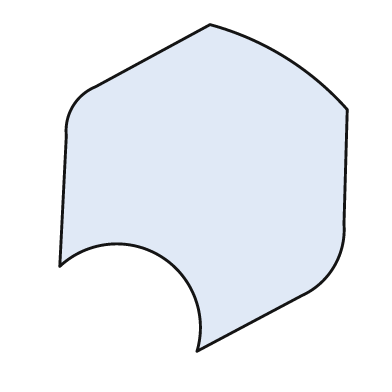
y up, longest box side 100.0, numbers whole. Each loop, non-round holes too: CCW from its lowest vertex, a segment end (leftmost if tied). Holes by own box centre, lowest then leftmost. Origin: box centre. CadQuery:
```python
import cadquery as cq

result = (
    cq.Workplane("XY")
    .moveTo(-2.0, -50.0)
    .lineTo(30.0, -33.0)
    .threePointArc((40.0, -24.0), (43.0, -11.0))
    .lineTo(44.0, 24.0)
    .threePointArc((25.0, 40.0), (2.0, 50.0))
    .lineTo(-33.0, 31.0)
    .threePointArc((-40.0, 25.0), (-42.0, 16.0))
    .lineTo(-44.0, -24.0)
    .threePointArc((-13.0, -21.0), (-2.0, -50.0))
    .close()
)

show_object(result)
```